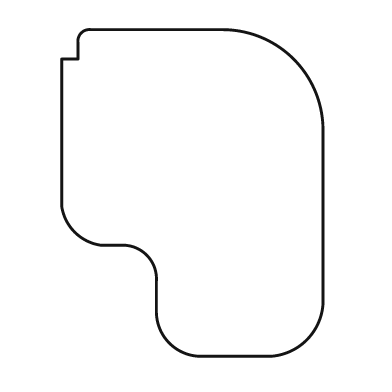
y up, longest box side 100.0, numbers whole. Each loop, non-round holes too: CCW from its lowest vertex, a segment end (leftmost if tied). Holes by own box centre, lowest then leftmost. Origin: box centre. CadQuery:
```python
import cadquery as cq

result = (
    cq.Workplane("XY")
    .moveTo(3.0, -50.0)
    .lineTo(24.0, -50.0)
    .threePointArc((35.0, -45.0), (40.0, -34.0))
    .lineTo(40.0, 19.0)
    .threePointArc((31.0, 41.0), (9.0, 50.0))
    .lineTo(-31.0, 50.0)
    .threePointArc((-34.0, 49.0), (-35.0, 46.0))
    .lineTo(-35.0, 41.0)
    .lineTo(-40.0, 41.0)
    .lineTo(-40.0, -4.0)
    .threePointArc((-36.0, -12.0), (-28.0, -16.0))
    .lineTo(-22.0, -16.0)
    .threePointArc((-14.0, -19.0), (-11.0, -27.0))
    .lineTo(-11.0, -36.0)
    .threePointArc((-7.0, -46.0), (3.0, -50.0))
    .close()
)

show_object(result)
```